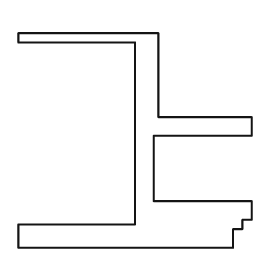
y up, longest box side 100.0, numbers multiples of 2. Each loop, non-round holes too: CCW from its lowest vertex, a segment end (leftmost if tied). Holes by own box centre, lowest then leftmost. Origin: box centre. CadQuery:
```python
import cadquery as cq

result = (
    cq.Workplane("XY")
    .moveTo(-50.0, -46.0)
    .lineTo(42.0, -46.0)
    .lineTo(42.0, -38.0)
    .lineTo(46.0, -38.0)
    .lineTo(46.0, -34.0)
    .lineTo(50.0, -34.0)
    .lineTo(50.0, -26.0)
    .lineTo(8.0, -26.0)
    .lineTo(8.0, 2.0)
    .lineTo(50.0, 2.0)
    .lineTo(50.0, 10.0)
    .lineTo(10.0, 10.0)
    .lineTo(10.0, 46.0)
    .lineTo(-50.0, 46.0)
    .lineTo(-50.0, 42.0)
    .lineTo(0.0, 42.0)
    .lineTo(0.0, -36.0)
    .lineTo(-50.0, -36.0)
    .close()
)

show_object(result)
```